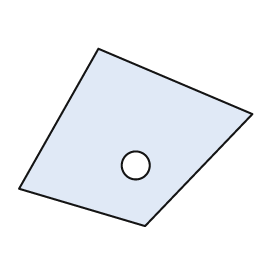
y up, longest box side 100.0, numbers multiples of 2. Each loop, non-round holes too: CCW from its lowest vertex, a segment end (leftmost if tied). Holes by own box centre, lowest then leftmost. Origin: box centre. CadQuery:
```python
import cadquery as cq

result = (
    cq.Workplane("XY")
    .moveTo(4.0, -38.0)
    .lineTo(50.0, 10.0)
    .lineTo(-16.0, 38.0)
    .lineTo(-50.0, -22.0)
    .close()
    .moveTo(0.0, -12.0)
    .circle(6.0)
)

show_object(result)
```